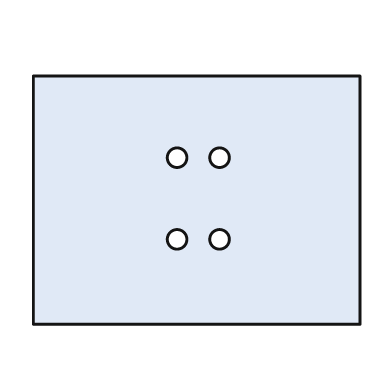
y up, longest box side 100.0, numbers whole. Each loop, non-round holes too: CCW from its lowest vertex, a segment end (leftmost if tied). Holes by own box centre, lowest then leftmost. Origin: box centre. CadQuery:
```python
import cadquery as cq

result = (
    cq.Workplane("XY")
    .moveTo(-50.0, -38.0)
    .lineTo(50.0, -38.0)
    .lineTo(50.0, 38.0)
    .lineTo(-50.0, 38.0)
    .close()
    .moveTo(-6.0, -12.0)
    .circle(3.0)
    .moveTo(7.0, -12.0)
    .circle(3.0)
    .moveTo(-6.0, 13.0)
    .circle(3.0)
    .moveTo(7.0, 13.0)
    .circle(3.0)
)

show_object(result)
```